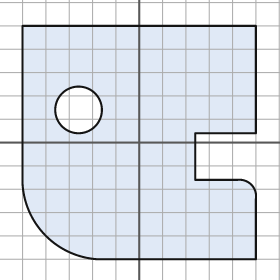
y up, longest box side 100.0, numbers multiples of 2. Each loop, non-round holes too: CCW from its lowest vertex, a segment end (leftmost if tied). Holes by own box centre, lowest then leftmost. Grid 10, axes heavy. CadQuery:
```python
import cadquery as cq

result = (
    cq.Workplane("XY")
    .moveTo(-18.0, -50.0)
    .lineTo(50.0, -50.0)
    .lineTo(50.0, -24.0)
    .threePointArc((48.0, -18.0), (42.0, -16.0))
    .lineTo(24.0, -16.0)
    .lineTo(24.0, 4.0)
    .lineTo(50.0, 4.0)
    .lineTo(50.0, 50.0)
    .lineTo(-50.0, 50.0)
    .lineTo(-50.0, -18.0)
    .threePointArc((-40.0, -40.0), (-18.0, -50.0))
    .close()
    .moveTo(-26.0, 14.0)
    .circle(10.0)
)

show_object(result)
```